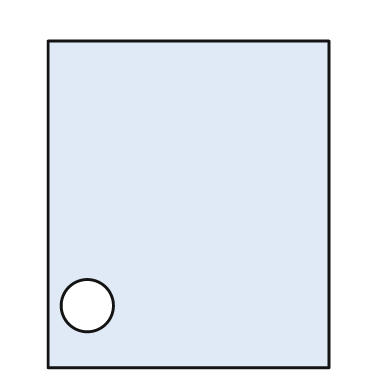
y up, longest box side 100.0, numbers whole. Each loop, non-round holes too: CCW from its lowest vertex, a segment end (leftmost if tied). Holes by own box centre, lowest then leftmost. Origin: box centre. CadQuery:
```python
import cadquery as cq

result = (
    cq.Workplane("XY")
    .moveTo(-43.0, -50.0)
    .lineTo(43.0, -50.0)
    .lineTo(43.0, 50.0)
    .lineTo(-43.0, 50.0)
    .close()
    .moveTo(-31.0, -31.0)
    .circle(8.0)
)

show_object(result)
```